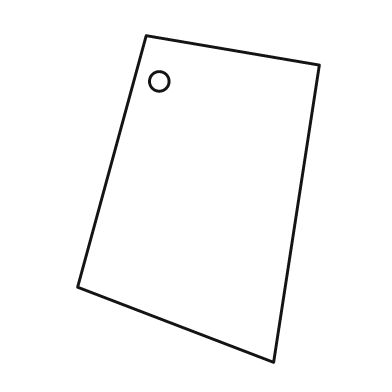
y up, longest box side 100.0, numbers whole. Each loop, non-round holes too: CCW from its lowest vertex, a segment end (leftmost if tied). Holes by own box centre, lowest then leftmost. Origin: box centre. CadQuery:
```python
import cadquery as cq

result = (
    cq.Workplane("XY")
    .moveTo(23.0, -50.0)
    .lineTo(37.0, 41.0)
    .lineTo(-16.0, 50.0)
    .lineTo(-37.0, -27.0)
    .close()
    .moveTo(-12.0, 36.0)
    .circle(3.0)
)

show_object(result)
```